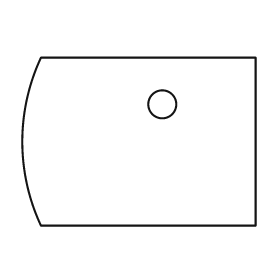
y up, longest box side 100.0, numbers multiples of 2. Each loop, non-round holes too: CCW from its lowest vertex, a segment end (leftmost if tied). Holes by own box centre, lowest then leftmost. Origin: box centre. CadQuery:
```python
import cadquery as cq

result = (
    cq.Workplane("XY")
    .moveTo(-42.0, -36.0)
    .lineTo(50.0, -36.0)
    .lineTo(50.0, 36.0)
    .lineTo(-42.0, 36.0)
    .threePointArc((-50.0, 0.0), (-42.0, -36.0))
    .close()
    .moveTo(10.0, 16.0)
    .circle(6.0)
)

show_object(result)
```